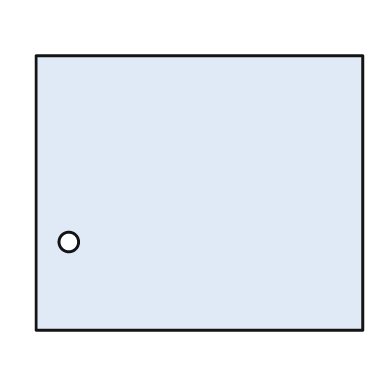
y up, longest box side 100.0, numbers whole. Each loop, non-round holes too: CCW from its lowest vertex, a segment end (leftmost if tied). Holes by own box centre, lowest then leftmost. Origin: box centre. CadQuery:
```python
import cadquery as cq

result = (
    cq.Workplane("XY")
    .moveTo(-50.0, -42.0)
    .lineTo(50.0, -42.0)
    .lineTo(50.0, 42.0)
    .lineTo(-50.0, 42.0)
    .close()
    .moveTo(-40.0, -15.0)
    .circle(3.0)
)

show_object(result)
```